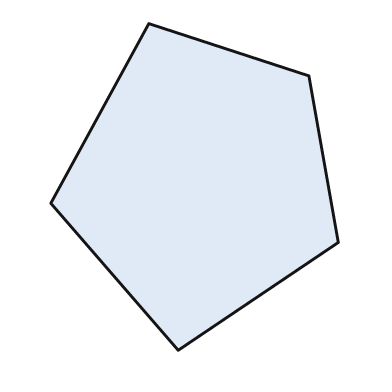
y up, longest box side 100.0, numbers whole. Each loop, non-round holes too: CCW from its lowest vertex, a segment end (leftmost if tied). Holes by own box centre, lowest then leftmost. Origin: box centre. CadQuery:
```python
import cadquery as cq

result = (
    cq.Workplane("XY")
    .moveTo(-5.0, -50.0)
    .lineTo(44.0, -17.0)
    .lineTo(35.0, 34.0)
    .lineTo(-14.0, 50.0)
    .lineTo(-44.0, -5.0)
    .close()
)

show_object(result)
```